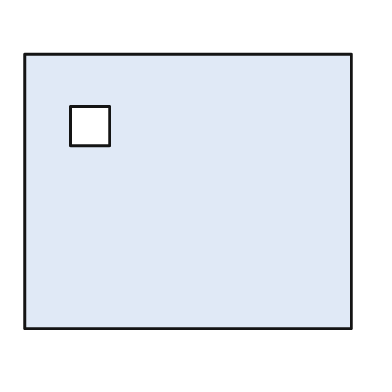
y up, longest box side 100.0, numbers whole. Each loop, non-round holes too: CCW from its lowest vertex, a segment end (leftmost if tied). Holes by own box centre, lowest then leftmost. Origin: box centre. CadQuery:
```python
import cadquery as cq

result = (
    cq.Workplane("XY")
    .moveTo(-50.0, -42.0)
    .lineTo(50.0, -42.0)
    .lineTo(50.0, 42.0)
    .lineTo(-50.0, 42.0)
    .close()
    .moveTo(-36.0, 14.0)
    .lineTo(-24.0, 14.0)
    .lineTo(-24.0, 26.0)
    .lineTo(-36.0, 26.0)
    .close()
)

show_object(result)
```